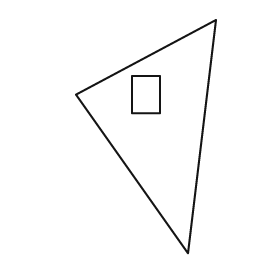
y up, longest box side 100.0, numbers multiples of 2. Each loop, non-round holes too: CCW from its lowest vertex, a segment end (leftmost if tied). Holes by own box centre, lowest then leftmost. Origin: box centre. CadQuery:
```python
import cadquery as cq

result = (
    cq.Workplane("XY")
    .moveTo(18.0, -50.0)
    .lineTo(30.0, 50.0)
    .lineTo(-30.0, 18.0)
    .close()
    .moveTo(-6.0, 10.0)
    .lineTo(6.0, 10.0)
    .lineTo(6.0, 26.0)
    .lineTo(-6.0, 26.0)
    .close()
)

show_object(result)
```